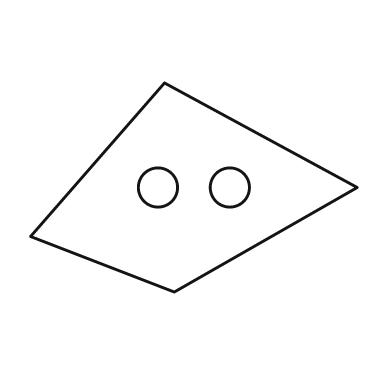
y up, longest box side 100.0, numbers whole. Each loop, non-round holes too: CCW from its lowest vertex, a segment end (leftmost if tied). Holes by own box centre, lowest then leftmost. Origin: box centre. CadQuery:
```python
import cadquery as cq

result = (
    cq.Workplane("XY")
    .moveTo(-6.0, -32.0)
    .lineTo(50.0, 0.0)
    .lineTo(-9.0, 32.0)
    .lineTo(-50.0, -15.0)
    .close()
    .moveTo(-11.0, 0.0)
    .circle(6.0)
    .moveTo(11.0, 0.0)
    .circle(6.0)
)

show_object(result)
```